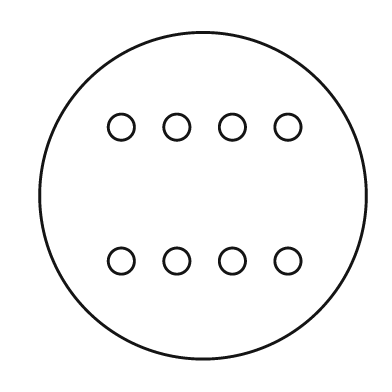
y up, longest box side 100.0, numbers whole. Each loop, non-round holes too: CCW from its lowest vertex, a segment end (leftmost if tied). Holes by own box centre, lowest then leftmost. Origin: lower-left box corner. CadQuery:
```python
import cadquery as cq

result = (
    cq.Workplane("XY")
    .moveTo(50.0, 50.0)
    .circle(50.0)
    .moveTo(25.0, 30.0)
    .circle(4.0)
    .moveTo(42.0, 30.0)
    .circle(4.0)
    .moveTo(59.0, 30.0)
    .circle(4.0)
    .moveTo(76.0, 30.0)
    .circle(4.0)
    .moveTo(25.0, 71.0)
    .circle(4.0)
    .moveTo(42.0, 71.0)
    .circle(4.0)
    .moveTo(59.0, 71.0)
    .circle(4.0)
    .moveTo(76.0, 71.0)
    .circle(4.0)
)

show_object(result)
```